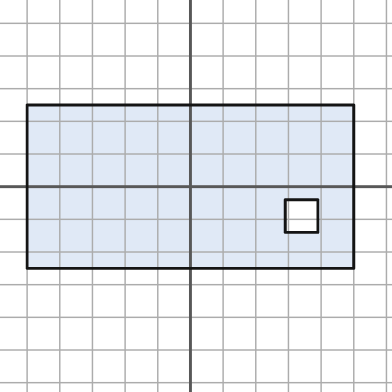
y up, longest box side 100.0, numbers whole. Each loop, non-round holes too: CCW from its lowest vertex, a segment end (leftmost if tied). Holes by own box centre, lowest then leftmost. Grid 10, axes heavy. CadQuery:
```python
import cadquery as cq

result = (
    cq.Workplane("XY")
    .moveTo(-50.0, -25.0)
    .lineTo(50.0, -25.0)
    .lineTo(50.0, 25.0)
    .lineTo(-50.0, 25.0)
    .close()
    .moveTo(29.0, -14.0)
    .lineTo(39.0, -14.0)
    .lineTo(39.0, -4.0)
    .lineTo(29.0, -4.0)
    .close()
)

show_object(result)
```